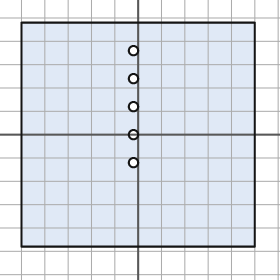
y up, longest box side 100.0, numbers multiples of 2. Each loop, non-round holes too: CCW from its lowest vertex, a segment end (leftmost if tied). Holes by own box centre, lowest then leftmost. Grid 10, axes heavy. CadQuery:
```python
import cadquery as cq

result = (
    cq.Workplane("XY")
    .moveTo(-50.0, -48.0)
    .lineTo(50.0, -48.0)
    .lineTo(50.0, 48.0)
    .lineTo(-50.0, 48.0)
    .close()
    .moveTo(-2.0, -12.0)
    .circle(2.0)
    .moveTo(-2.0, 0.0)
    .circle(2.0)
    .moveTo(-2.0, 12.0)
    .circle(2.0)
    .moveTo(-2.0, 24.0)
    .circle(2.0)
    .moveTo(-2.0, 36.0)
    .circle(2.0)
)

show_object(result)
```